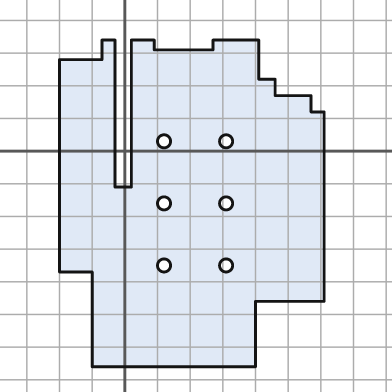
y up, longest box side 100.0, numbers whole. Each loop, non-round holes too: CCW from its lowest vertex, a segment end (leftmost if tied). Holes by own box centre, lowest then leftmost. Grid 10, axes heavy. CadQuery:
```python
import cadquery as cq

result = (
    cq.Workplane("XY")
    .moveTo(-10.0, -66.0)
    .lineTo(40.0, -66.0)
    .lineTo(40.0, -46.0)
    .lineTo(61.0, -46.0)
    .lineTo(61.0, 12.0)
    .lineTo(57.0, 12.0)
    .lineTo(57.0, 17.0)
    .lineTo(46.0, 17.0)
    .lineTo(46.0, 22.0)
    .lineTo(41.0, 22.0)
    .lineTo(41.0, 34.0)
    .lineTo(27.0, 34.0)
    .lineTo(27.0, 31.0)
    .lineTo(9.0, 31.0)
    .lineTo(9.0, 34.0)
    .lineTo(2.0, 34.0)
    .lineTo(2.0, -11.0)
    .lineTo(-3.0, -11.0)
    .lineTo(-3.0, 34.0)
    .lineTo(-7.0, 34.0)
    .lineTo(-7.0, 28.0)
    .lineTo(-20.0, 28.0)
    .lineTo(-20.0, -37.0)
    .lineTo(-10.0, -37.0)
    .close()
    .moveTo(12.0, -35.0)
    .circle(2.0)
    .moveTo(31.0, -35.0)
    .circle(2.0)
    .moveTo(12.0, -16.0)
    .circle(2.0)
    .moveTo(31.0, -16.0)
    .circle(2.0)
    .moveTo(12.0, 3.0)
    .circle(2.0)
    .moveTo(31.0, 3.0)
    .circle(2.0)
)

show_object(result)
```